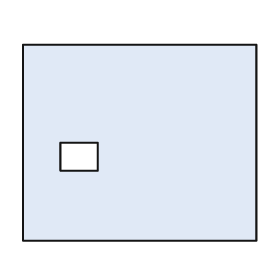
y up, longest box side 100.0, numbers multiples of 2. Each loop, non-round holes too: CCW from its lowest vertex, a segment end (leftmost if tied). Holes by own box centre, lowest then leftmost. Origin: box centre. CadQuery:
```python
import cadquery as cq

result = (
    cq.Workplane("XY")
    .moveTo(-50.0, -42.0)
    .lineTo(50.0, -42.0)
    .lineTo(50.0, 42.0)
    .lineTo(-50.0, 42.0)
    .close()
    .moveTo(-34.0, -12.0)
    .lineTo(-18.0, -12.0)
    .lineTo(-18.0, 0.0)
    .lineTo(-34.0, 0.0)
    .close()
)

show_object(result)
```